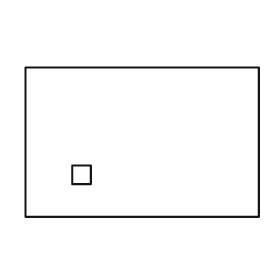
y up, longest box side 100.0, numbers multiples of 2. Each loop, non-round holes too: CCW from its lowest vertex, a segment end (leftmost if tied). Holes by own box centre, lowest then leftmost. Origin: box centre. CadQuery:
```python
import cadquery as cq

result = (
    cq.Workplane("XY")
    .moveTo(-50.0, -32.0)
    .lineTo(50.0, -32.0)
    .lineTo(50.0, 32.0)
    .lineTo(-50.0, 32.0)
    .close()
    .moveTo(-30.0, -18.0)
    .lineTo(-22.0, -18.0)
    .lineTo(-22.0, -10.0)
    .lineTo(-30.0, -10.0)
    .close()
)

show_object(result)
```